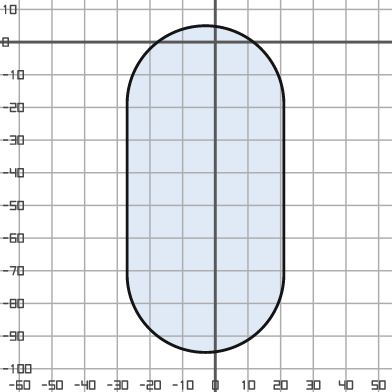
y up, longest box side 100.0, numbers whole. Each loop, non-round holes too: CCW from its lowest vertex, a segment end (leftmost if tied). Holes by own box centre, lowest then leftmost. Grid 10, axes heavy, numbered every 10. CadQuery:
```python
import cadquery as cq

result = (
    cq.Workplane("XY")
    .moveTo(-27.0, -71.0)
    .threePointArc((-3.0, -95.0), (21.0, -71.0))
    .lineTo(21.0, -19.0)
    .threePointArc((-3.0, 5.0), (-27.0, -19.0))
    .close()
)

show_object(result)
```